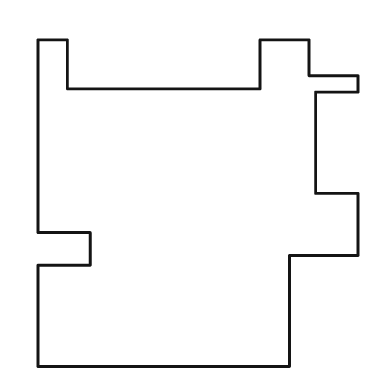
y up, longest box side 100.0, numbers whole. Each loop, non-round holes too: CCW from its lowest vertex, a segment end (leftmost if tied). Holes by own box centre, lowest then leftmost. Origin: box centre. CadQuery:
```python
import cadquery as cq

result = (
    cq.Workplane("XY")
    .moveTo(-49.0, -50.0)
    .lineTo(28.0, -50.0)
    .lineTo(28.0, -16.0)
    .lineTo(49.0, -16.0)
    .lineTo(49.0, 3.0)
    .lineTo(36.0, 3.0)
    .lineTo(36.0, 34.0)
    .lineTo(49.0, 34.0)
    .lineTo(49.0, 39.0)
    .lineTo(34.0, 39.0)
    .lineTo(34.0, 50.0)
    .lineTo(19.0, 50.0)
    .lineTo(19.0, 35.0)
    .lineTo(-40.0, 35.0)
    .lineTo(-40.0, 50.0)
    .lineTo(-49.0, 50.0)
    .lineTo(-49.0, -9.0)
    .lineTo(-33.0, -9.0)
    .lineTo(-33.0, -19.0)
    .lineTo(-49.0, -19.0)
    .close()
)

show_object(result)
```